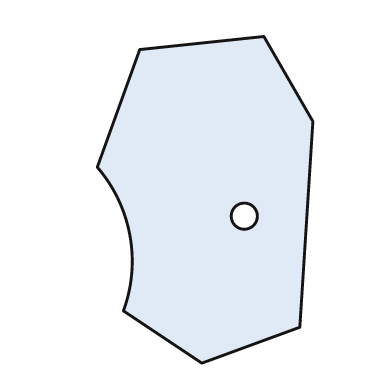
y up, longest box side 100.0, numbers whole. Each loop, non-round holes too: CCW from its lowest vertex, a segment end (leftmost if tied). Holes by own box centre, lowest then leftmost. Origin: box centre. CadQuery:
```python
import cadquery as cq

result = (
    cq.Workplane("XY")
    .moveTo(-1.0, -50.0)
    .lineTo(29.0, -39.0)
    .lineTo(33.0, 24.0)
    .lineTo(18.0, 50.0)
    .lineTo(-20.0, 46.0)
    .lineTo(-33.0, 10.0)
    .threePointArc((-23.0, -11.0), (-25.0, -34.0))
    .close()
    .moveTo(12.0, -5.0)
    .circle(4.0)
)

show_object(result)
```